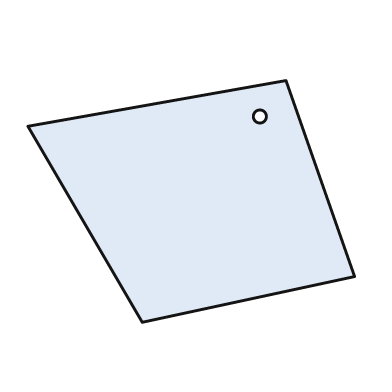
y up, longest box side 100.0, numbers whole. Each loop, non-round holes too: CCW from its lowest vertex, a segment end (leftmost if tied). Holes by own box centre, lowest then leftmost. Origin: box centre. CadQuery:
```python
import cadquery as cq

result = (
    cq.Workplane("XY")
    .moveTo(-15.0, -37.0)
    .lineTo(50.0, -23.0)
    .lineTo(29.0, 37.0)
    .lineTo(-50.0, 23.0)
    .close()
    .moveTo(21.0, 26.0)
    .circle(2.0)
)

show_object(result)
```